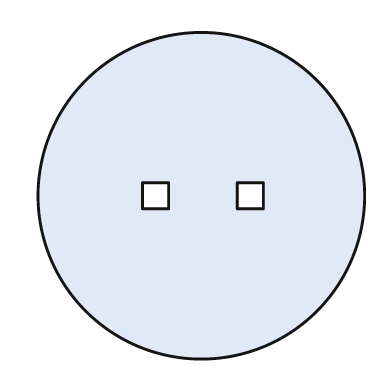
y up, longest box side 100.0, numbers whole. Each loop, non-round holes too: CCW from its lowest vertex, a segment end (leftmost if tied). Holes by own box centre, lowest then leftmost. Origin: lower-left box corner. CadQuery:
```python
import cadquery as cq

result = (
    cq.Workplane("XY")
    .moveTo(50.0, 50.0)
    .circle(50.0)
    .moveTo(32.0, 46.0)
    .lineTo(40.0, 46.0)
    .lineTo(40.0, 54.0)
    .lineTo(32.0, 54.0)
    .close()
    .moveTo(61.0, 46.0)
    .lineTo(69.0, 46.0)
    .lineTo(69.0, 54.0)
    .lineTo(61.0, 54.0)
    .close()
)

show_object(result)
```